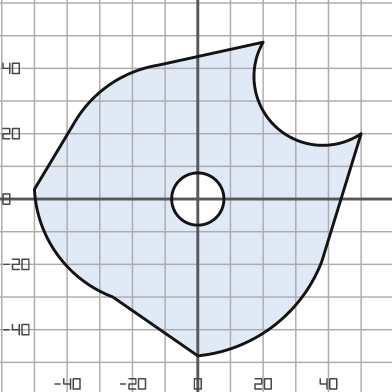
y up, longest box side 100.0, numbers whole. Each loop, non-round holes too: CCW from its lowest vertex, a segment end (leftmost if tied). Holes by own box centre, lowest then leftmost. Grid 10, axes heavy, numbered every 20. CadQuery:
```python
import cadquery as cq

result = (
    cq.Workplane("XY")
    .moveTo(0.0, -48.0)
    .threePointArc((23.0, -39.0), (38.0, -19.0))
    .lineTo(50.0, 20.0)
    .threePointArc((24.0, 22.0), (20.0, 48.0))
    .lineTo(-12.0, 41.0)
    .threePointArc((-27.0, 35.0), (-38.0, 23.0))
    .lineTo(-50.0, 3.0)
    .threePointArc((-43.0, -17.0), (-26.0, -30.0))
    .close()
    .moveTo(0.0, 0.0)
    .circle(8.0)
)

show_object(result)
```